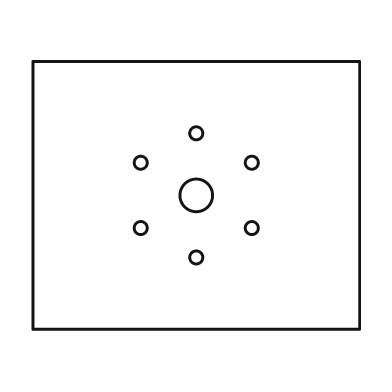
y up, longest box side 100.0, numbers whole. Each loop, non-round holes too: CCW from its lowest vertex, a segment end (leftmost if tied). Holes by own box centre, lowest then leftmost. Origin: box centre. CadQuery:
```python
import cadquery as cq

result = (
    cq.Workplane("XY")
    .moveTo(-50.0, -41.0)
    .lineTo(50.0, -41.0)
    .lineTo(50.0, 41.0)
    .lineTo(-50.0, 41.0)
    .close()
    .moveTo(0.0, -19.0)
    .circle(2.0)
    .moveTo(-17.0, -10.0)
    .circle(2.0)
    .moveTo(17.0, -10.0)
    .circle(2.0)
    .moveTo(0.0, 0.0)
    .circle(5.0)
    .moveTo(-17.0, 10.0)
    .circle(2.0)
    .moveTo(17.0, 10.0)
    .circle(2.0)
    .moveTo(0.0, 19.0)
    .circle(2.0)
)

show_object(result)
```